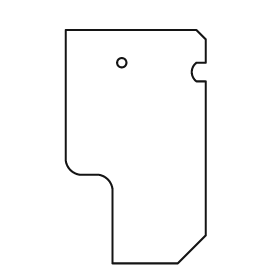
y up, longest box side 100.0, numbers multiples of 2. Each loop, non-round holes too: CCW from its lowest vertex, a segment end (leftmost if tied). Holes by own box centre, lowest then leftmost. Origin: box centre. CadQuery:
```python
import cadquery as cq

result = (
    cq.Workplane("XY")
    .moveTo(-10.0, -50.0)
    .lineTo(18.0, -50.0)
    .lineTo(30.0, -38.0)
    .lineTo(30.0, 28.0)
    .lineTo(26.0, 28.0)
    .threePointArc((24.0, 32.0), (26.0, 36.0))
    .lineTo(30.0, 36.0)
    .lineTo(30.0, 46.0)
    .lineTo(26.0, 50.0)
    .lineTo(-30.0, 50.0)
    .lineTo(-30.0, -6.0)
    .threePointArc((-28.0, -10.0), (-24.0, -12.0))
    .lineTo(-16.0, -12.0)
    .threePointArc((-12.0, -14.0), (-10.0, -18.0))
    .close()
    .moveTo(-6.0, 36.0)
    .circle(2.0)
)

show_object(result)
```